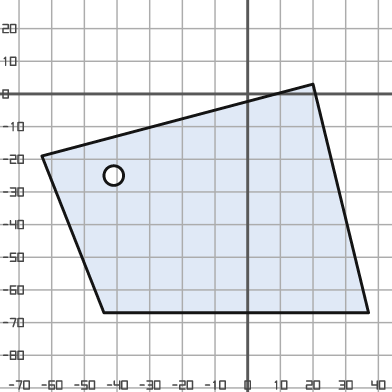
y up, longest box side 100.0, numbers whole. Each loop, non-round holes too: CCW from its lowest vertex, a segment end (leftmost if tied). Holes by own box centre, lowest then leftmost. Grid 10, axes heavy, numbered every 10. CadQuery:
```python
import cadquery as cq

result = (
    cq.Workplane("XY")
    .moveTo(-44.0, -67.0)
    .lineTo(37.0, -67.0)
    .lineTo(20.0, 3.0)
    .lineTo(-63.0, -19.0)
    .close()
    .moveTo(-41.0, -25.0)
    .circle(3.0)
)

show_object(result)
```